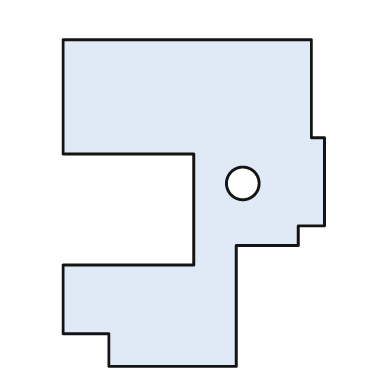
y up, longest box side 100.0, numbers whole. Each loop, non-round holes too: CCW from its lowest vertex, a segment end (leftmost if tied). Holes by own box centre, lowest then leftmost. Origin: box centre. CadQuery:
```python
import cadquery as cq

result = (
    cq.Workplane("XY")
    .moveTo(-26.0, -50.0)
    .lineTo(13.0, -50.0)
    .lineTo(13.0, -13.0)
    .lineTo(32.0, -13.0)
    .lineTo(32.0, -7.0)
    .lineTo(40.0, -7.0)
    .lineTo(40.0, 20.0)
    .lineTo(36.0, 20.0)
    .lineTo(36.0, 50.0)
    .lineTo(-40.0, 50.0)
    .lineTo(-40.0, 15.0)
    .lineTo(0.0, 15.0)
    .lineTo(0.0, -19.0)
    .lineTo(-40.0, -19.0)
    .lineTo(-40.0, -40.0)
    .lineTo(-26.0, -40.0)
    .close()
    .moveTo(15.0, 6.0)
    .circle(5.0)
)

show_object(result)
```